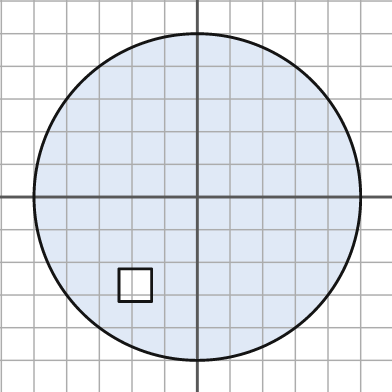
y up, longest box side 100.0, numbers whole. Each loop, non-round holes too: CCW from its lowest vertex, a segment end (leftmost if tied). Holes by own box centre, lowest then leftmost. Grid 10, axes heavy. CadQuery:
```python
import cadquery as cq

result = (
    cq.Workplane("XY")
    .moveTo(0.0, 0.0)
    .circle(50.0)
    .moveTo(-24.0, -32.0)
    .lineTo(-14.0, -32.0)
    .lineTo(-14.0, -22.0)
    .lineTo(-24.0, -22.0)
    .close()
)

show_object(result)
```